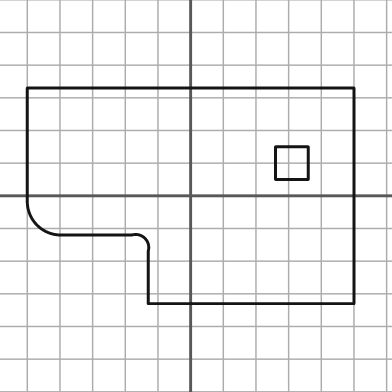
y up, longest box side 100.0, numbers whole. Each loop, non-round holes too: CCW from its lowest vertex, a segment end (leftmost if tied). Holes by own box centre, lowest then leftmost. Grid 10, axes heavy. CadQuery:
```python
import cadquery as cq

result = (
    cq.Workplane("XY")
    .moveTo(-13.0, -33.0)
    .lineTo(50.0, -33.0)
    .lineTo(50.0, 33.0)
    .lineTo(-50.0, 33.0)
    .lineTo(-50.0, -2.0)
    .threePointArc((-47.0, -9.0), (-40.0, -12.0))
    .lineTo(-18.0, -12.0)
    .threePointArc((-14.0, -13.0), (-13.0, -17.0))
    .close()
    .moveTo(26.0, 5.0)
    .lineTo(36.0, 5.0)
    .lineTo(36.0, 15.0)
    .lineTo(26.0, 15.0)
    .close()
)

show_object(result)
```